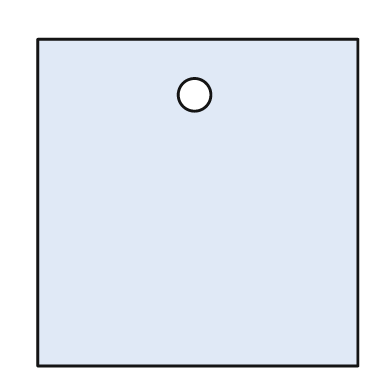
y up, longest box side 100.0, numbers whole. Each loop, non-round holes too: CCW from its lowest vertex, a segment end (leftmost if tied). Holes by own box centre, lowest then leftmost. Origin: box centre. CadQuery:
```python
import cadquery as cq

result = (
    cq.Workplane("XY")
    .moveTo(-49.0, -50.0)
    .lineTo(49.0, -50.0)
    .lineTo(49.0, 50.0)
    .lineTo(-49.0, 50.0)
    .close()
    .moveTo(-1.0, 33.0)
    .circle(5.0)
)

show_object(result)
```